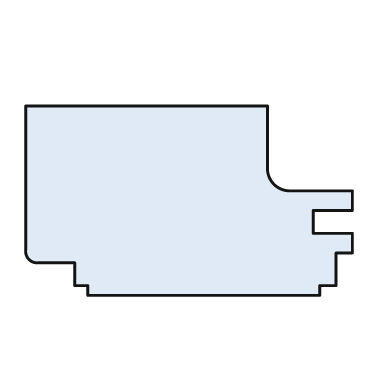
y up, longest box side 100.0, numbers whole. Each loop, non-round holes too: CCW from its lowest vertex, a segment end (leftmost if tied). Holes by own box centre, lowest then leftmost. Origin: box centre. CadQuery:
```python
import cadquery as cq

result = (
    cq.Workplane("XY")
    .moveTo(-31.0, -29.0)
    .lineTo(40.0, -29.0)
    .lineTo(40.0, -26.0)
    .lineTo(45.0, -26.0)
    .lineTo(45.0, -16.0)
    .lineTo(50.0, -16.0)
    .lineTo(50.0, -10.0)
    .lineTo(38.0, -10.0)
    .lineTo(38.0, -3.0)
    .lineTo(50.0, -3.0)
    .lineTo(50.0, 3.0)
    .lineTo(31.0, 3.0)
    .threePointArc((26.0, 5.0), (24.0, 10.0))
    .lineTo(24.0, 29.0)
    .lineTo(-50.0, 29.0)
    .lineTo(-50.0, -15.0)
    .threePointArc((-49.0, -18.0), (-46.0, -19.0))
    .lineTo(-35.0, -19.0)
    .lineTo(-35.0, -26.0)
    .lineTo(-31.0, -26.0)
    .close()
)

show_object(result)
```